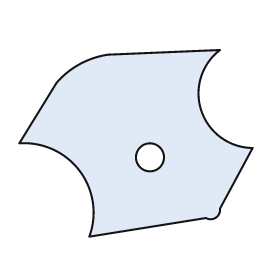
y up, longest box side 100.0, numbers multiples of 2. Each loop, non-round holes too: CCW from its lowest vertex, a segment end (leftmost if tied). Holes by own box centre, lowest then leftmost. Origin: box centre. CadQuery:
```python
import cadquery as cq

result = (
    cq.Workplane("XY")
    .moveTo(-20.0, -40.0)
    .lineTo(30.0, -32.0)
    .threePointArc((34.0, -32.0), (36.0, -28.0))
    .lineTo(50.0, -2.0)
    .threePointArc((28.0, 14.0), (36.0, 40.0))
    .lineTo(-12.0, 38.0)
    .threePointArc((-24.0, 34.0), (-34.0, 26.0))
    .lineTo(-50.0, 0.0)
    .threePointArc((-24.0, -12.0), (-20.0, -40.0))
    .close()
    .moveTo(6.0, -6.0)
    .circle(6.0)
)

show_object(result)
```